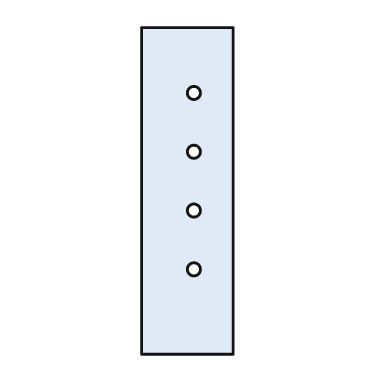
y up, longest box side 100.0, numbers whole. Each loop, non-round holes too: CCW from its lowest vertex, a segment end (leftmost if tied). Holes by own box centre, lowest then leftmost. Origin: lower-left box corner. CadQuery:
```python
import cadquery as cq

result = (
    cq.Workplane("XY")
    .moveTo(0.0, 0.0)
    .lineTo(28.0, 0.0)
    .lineTo(28.0, 100.0)
    .lineTo(0.0, 100.0)
    .close()
    .moveTo(16.0, 26.0)
    .circle(2.0)
    .moveTo(16.0, 44.0)
    .circle(2.0)
    .moveTo(16.0, 62.0)
    .circle(2.0)
    .moveTo(16.0, 80.0)
    .circle(2.0)
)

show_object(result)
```